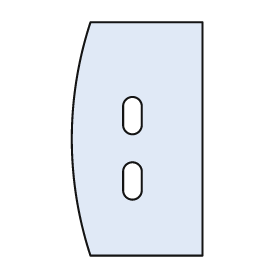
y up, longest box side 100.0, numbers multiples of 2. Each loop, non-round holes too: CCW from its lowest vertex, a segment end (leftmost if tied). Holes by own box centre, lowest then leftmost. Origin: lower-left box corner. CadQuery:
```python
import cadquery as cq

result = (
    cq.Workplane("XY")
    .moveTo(8.0, 0.0)
    .lineTo(56.0, 0.0)
    .lineTo(56.0, 100.0)
    .lineTo(8.0, 100.0)
    .threePointArc((0.0, 50.0), (8.0, 0.0))
    .close()
    .moveTo(22.0, 28.0)
    .threePointArc((26.0, 24.0), (30.0, 28.0))
    .lineTo(30.0, 36.0)
    .threePointArc((26.0, 40.0), (22.0, 36.0))
    .close()
    .moveTo(22.0, 56.0)
    .threePointArc((26.0, 52.0), (30.0, 56.0))
    .lineTo(30.0, 64.0)
    .threePointArc((26.0, 68.0), (22.0, 64.0))
    .close()
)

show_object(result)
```